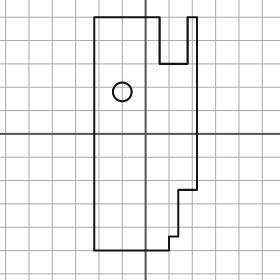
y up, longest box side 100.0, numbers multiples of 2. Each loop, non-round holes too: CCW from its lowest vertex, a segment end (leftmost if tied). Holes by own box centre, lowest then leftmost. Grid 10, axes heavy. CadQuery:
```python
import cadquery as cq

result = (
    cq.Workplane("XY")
    .moveTo(-22.0, -50.0)
    .lineTo(10.0, -50.0)
    .lineTo(10.0, -44.0)
    .lineTo(14.0, -44.0)
    .lineTo(14.0, -24.0)
    .lineTo(22.0, -24.0)
    .lineTo(22.0, 50.0)
    .lineTo(18.0, 50.0)
    .lineTo(18.0, 30.0)
    .lineTo(6.0, 30.0)
    .lineTo(6.0, 50.0)
    .lineTo(-22.0, 50.0)
    .close()
    .moveTo(-10.0, 18.0)
    .circle(4.0)
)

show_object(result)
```